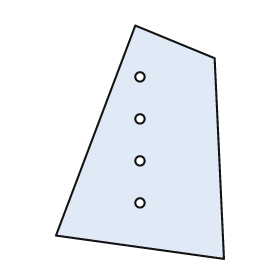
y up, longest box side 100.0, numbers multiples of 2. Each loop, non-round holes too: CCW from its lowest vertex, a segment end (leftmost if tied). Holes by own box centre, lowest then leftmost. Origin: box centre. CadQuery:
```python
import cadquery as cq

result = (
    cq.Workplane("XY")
    .moveTo(36.0, -50.0)
    .lineTo(32.0, 36.0)
    .lineTo(-2.0, 50.0)
    .lineTo(-36.0, -40.0)
    .close()
    .moveTo(0.0, -26.0)
    .circle(2.0)
    .moveTo(0.0, -8.0)
    .circle(2.0)
    .moveTo(0.0, 10.0)
    .circle(2.0)
    .moveTo(0.0, 28.0)
    .circle(2.0)
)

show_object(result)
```